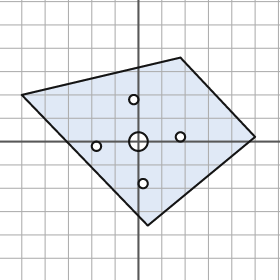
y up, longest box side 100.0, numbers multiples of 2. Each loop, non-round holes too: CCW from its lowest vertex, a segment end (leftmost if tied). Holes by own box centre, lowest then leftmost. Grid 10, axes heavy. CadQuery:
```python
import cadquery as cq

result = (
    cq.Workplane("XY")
    .moveTo(4.0, -36.0)
    .lineTo(50.0, 2.0)
    .lineTo(18.0, 36.0)
    .lineTo(-50.0, 20.0)
    .close()
    .moveTo(2.0, -18.0)
    .circle(2.0)
    .moveTo(-18.0, -2.0)
    .circle(2.0)
    .moveTo(0.0, 0.0)
    .circle(4.0)
    .moveTo(18.0, 2.0)
    .circle(2.0)
    .moveTo(-2.0, 18.0)
    .circle(2.0)
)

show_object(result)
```